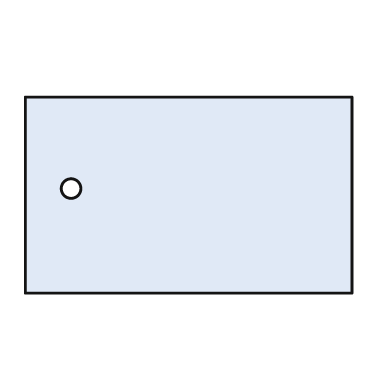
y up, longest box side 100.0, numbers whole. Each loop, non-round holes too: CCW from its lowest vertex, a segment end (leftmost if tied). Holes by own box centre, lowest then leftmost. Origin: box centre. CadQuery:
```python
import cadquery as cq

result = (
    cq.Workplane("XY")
    .moveTo(-50.0, -30.0)
    .lineTo(50.0, -30.0)
    .lineTo(50.0, 30.0)
    .lineTo(-50.0, 30.0)
    .close()
    .moveTo(-36.0, 2.0)
    .circle(3.0)
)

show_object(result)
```